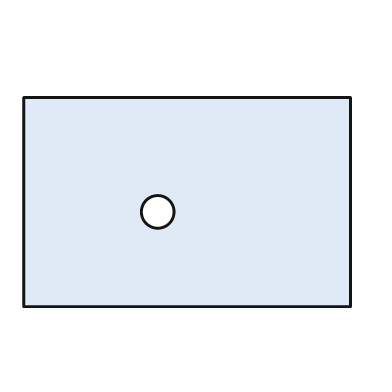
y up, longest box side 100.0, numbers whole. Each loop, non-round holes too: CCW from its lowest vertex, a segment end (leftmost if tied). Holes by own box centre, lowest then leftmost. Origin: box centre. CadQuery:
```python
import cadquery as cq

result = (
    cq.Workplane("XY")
    .moveTo(-50.0, -32.0)
    .lineTo(50.0, -32.0)
    .lineTo(50.0, 32.0)
    .lineTo(-50.0, 32.0)
    .close()
    .moveTo(-9.0, -3.0)
    .circle(5.0)
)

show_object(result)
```